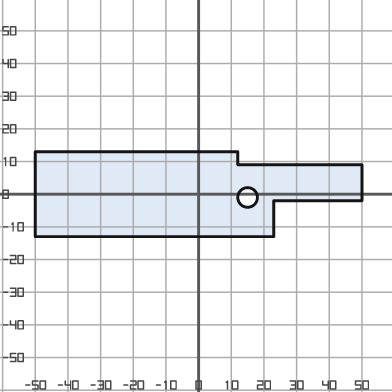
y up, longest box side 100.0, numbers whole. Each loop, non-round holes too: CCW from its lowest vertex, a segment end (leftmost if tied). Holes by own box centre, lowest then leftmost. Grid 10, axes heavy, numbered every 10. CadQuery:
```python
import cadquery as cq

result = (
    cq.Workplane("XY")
    .moveTo(-50.0, -13.0)
    .lineTo(23.0, -13.0)
    .lineTo(23.0, -2.0)
    .lineTo(50.0, -2.0)
    .lineTo(50.0, 9.0)
    .lineTo(12.0, 9.0)
    .lineTo(12.0, 13.0)
    .lineTo(-50.0, 13.0)
    .close()
    .moveTo(15.0, -1.0)
    .circle(3.0)
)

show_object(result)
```